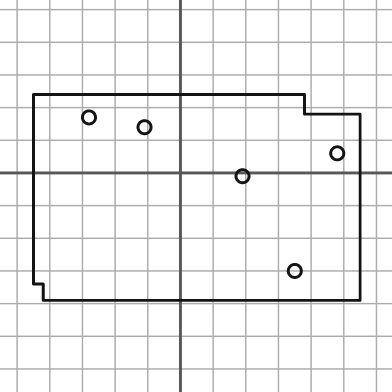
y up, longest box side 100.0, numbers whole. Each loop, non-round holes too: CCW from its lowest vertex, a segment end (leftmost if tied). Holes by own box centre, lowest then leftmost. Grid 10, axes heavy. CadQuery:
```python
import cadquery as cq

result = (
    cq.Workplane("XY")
    .moveTo(-42.0, -39.0)
    .lineTo(55.0, -39.0)
    .lineTo(55.0, 18.0)
    .lineTo(38.0, 18.0)
    .lineTo(38.0, 24.0)
    .lineTo(-45.0, 24.0)
    .lineTo(-45.0, -34.0)
    .lineTo(-42.0, -34.0)
    .close()
    .moveTo(35.0, -30.0)
    .circle(2.0)
    .moveTo(19.0, -1.0)
    .circle(2.0)
    .moveTo(48.0, 6.0)
    .circle(2.0)
    .moveTo(-11.0, 14.0)
    .circle(2.0)
    .moveTo(-28.0, 17.0)
    .circle(2.0)
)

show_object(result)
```